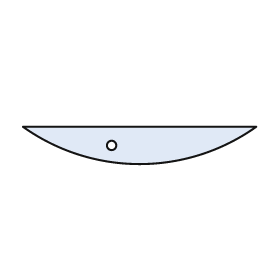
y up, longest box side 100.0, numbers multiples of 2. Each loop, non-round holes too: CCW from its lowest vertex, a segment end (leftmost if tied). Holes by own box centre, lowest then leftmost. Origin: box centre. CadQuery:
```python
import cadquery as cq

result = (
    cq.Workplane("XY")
    .moveTo(-50.0, 8.0)
    .threePointArc((0.0, -8.0), (50.0, 8.0))
    .close()
    .moveTo(-12.0, 0.0)
    .circle(2.0)
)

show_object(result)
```